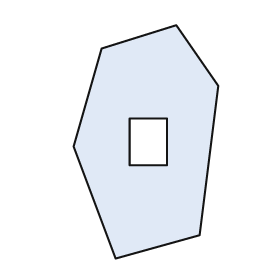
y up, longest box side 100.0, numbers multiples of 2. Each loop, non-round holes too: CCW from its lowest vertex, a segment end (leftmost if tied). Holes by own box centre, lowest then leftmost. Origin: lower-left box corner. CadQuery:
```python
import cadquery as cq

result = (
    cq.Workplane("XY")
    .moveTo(18.0, 0.0)
    .lineTo(54.0, 10.0)
    .lineTo(62.0, 74.0)
    .lineTo(44.0, 100.0)
    .lineTo(12.0, 90.0)
    .lineTo(0.0, 48.0)
    .close()
    .moveTo(24.0, 40.0)
    .lineTo(40.0, 40.0)
    .lineTo(40.0, 60.0)
    .lineTo(24.0, 60.0)
    .close()
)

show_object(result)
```